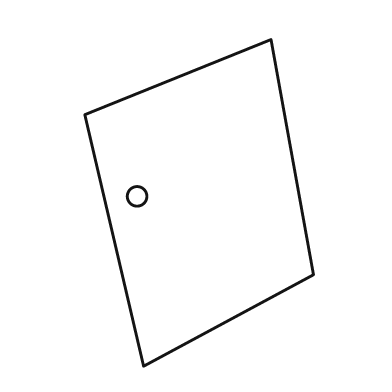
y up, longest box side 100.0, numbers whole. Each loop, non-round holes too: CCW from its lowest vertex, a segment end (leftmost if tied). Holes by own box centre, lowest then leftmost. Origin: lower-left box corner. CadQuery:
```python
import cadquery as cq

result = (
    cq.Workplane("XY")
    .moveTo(18.0, 0.0)
    .lineTo(70.0, 28.0)
    .lineTo(57.0, 100.0)
    .lineTo(0.0, 77.0)
    .close()
    .moveTo(16.0, 52.0)
    .circle(3.0)
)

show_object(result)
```